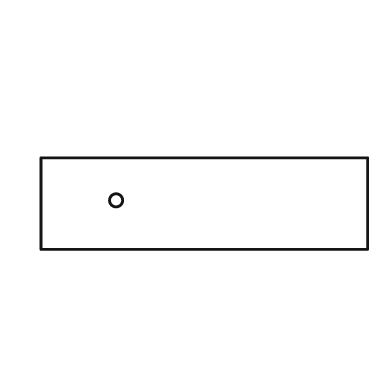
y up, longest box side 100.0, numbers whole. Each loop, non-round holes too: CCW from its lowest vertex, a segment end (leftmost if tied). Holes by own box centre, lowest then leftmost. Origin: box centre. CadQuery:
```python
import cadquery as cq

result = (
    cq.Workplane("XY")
    .moveTo(-50.0, -14.0)
    .lineTo(50.0, -14.0)
    .lineTo(50.0, 14.0)
    .lineTo(-50.0, 14.0)
    .close()
    .moveTo(-27.0, 1.0)
    .circle(2.0)
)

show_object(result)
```